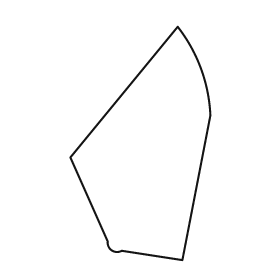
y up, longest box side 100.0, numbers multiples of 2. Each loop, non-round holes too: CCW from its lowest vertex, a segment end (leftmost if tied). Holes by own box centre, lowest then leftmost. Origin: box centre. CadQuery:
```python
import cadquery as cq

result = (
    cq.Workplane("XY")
    .moveTo(18.0, -50.0)
    .lineTo(30.0, 12.0)
    .threePointArc((26.0, 32.0), (16.0, 50.0))
    .lineTo(-30.0, -6.0)
    .lineTo(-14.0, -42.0)
    .threePointArc((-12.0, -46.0), (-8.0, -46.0))
    .close()
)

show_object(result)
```